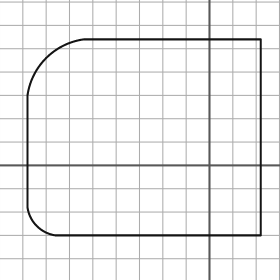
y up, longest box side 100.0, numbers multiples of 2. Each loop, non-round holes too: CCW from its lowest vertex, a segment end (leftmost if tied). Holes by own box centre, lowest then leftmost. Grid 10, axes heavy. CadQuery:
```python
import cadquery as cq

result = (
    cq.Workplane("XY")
    .moveTo(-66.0, -30.0)
    .lineTo(22.0, -30.0)
    .lineTo(22.0, 54.0)
    .lineTo(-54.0, 54.0)
    .threePointArc((-70.0, 46.0), (-78.0, 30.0))
    .lineTo(-78.0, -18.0)
    .threePointArc((-74.0, -26.0), (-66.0, -30.0))
    .close()
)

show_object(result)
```